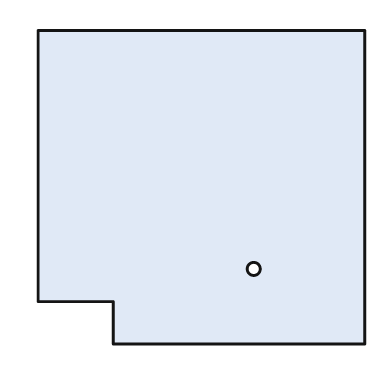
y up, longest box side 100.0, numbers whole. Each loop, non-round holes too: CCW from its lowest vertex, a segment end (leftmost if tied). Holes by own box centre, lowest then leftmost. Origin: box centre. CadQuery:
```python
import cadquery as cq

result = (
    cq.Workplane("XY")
    .moveTo(-27.0, -48.0)
    .lineTo(50.0, -48.0)
    .lineTo(50.0, 48.0)
    .lineTo(-50.0, 48.0)
    .lineTo(-50.0, -35.0)
    .lineTo(-27.0, -35.0)
    .close()
    .moveTo(16.0, -25.0)
    .circle(2.0)
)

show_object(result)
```